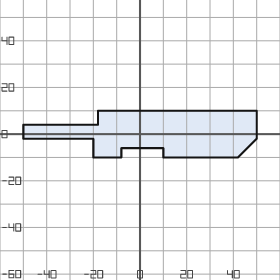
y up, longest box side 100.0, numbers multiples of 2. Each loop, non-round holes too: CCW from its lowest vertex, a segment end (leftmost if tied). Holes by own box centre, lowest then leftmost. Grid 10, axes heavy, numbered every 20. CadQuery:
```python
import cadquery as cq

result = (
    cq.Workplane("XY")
    .moveTo(-20.0, -10.0)
    .lineTo(-8.0, -10.0)
    .lineTo(-8.0, -6.0)
    .lineTo(10.0, -6.0)
    .lineTo(10.0, -10.0)
    .lineTo(42.0, -10.0)
    .lineTo(50.0, -2.0)
    .lineTo(50.0, 10.0)
    .lineTo(-18.0, 10.0)
    .lineTo(-18.0, 4.0)
    .lineTo(-50.0, 4.0)
    .lineTo(-50.0, -2.0)
    .lineTo(-20.0, -2.0)
    .close()
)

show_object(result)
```